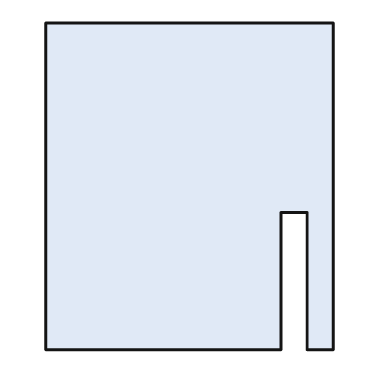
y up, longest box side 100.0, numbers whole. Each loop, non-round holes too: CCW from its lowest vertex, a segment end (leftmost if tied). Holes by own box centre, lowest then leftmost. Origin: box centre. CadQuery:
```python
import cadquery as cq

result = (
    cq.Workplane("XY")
    .moveTo(-44.0, -50.0)
    .lineTo(28.0, -50.0)
    .lineTo(28.0, -8.0)
    .lineTo(36.0, -8.0)
    .lineTo(36.0, -50.0)
    .lineTo(44.0, -50.0)
    .lineTo(44.0, 50.0)
    .lineTo(-44.0, 50.0)
    .close()
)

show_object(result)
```